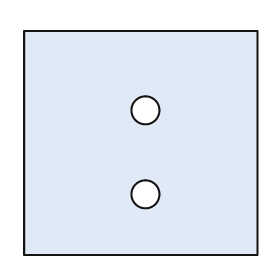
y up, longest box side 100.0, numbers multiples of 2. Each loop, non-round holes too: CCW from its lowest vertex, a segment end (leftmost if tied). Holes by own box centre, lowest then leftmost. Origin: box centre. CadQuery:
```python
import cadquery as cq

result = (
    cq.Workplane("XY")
    .moveTo(-50.0, -48.0)
    .lineTo(50.0, -48.0)
    .lineTo(50.0, 48.0)
    .lineTo(-50.0, 48.0)
    .close()
    .moveTo(2.0, -22.0)
    .circle(6.0)
    .moveTo(2.0, 14.0)
    .circle(6.0)
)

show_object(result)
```